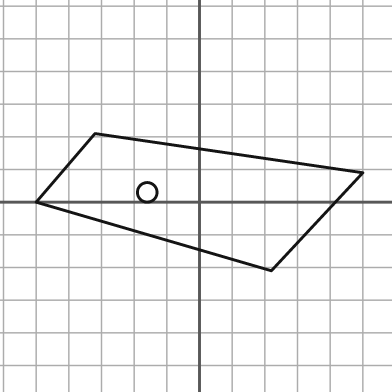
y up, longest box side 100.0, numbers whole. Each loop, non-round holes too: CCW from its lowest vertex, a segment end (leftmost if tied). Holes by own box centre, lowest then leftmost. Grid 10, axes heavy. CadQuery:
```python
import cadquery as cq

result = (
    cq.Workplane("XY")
    .moveTo(22.0, -21.0)
    .lineTo(50.0, 9.0)
    .lineTo(-32.0, 21.0)
    .lineTo(-50.0, 0.0)
    .close()
    .moveTo(-16.0, 3.0)
    .circle(3.0)
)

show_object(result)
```